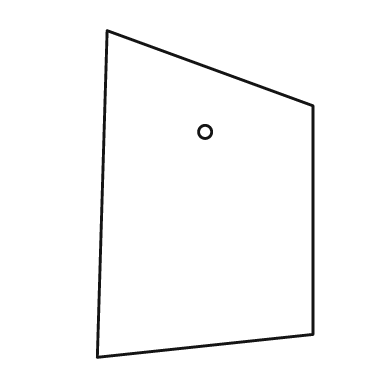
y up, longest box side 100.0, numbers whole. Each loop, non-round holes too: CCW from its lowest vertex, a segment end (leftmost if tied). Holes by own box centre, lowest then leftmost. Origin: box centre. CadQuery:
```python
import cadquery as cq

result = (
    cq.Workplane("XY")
    .moveTo(-33.0, -50.0)
    .lineTo(33.0, -43.0)
    .lineTo(33.0, 27.0)
    .lineTo(-30.0, 50.0)
    .close()
    .moveTo(0.0, 19.0)
    .circle(2.0)
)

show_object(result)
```